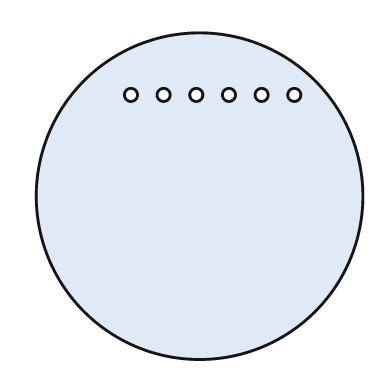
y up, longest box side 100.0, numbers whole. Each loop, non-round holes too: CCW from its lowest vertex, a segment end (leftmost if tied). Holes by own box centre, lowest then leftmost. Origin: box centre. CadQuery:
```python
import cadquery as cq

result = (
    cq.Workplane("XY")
    .moveTo(0.0, 0.0)
    .circle(50.0)
    .moveTo(-21.0, 31.0)
    .circle(2.0)
    .moveTo(-11.0, 31.0)
    .circle(2.0)
    .moveTo(-1.0, 31.0)
    .circle(2.0)
    .moveTo(9.0, 31.0)
    .circle(2.0)
    .moveTo(19.0, 31.0)
    .circle(2.0)
    .moveTo(29.0, 31.0)
    .circle(2.0)
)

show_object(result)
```